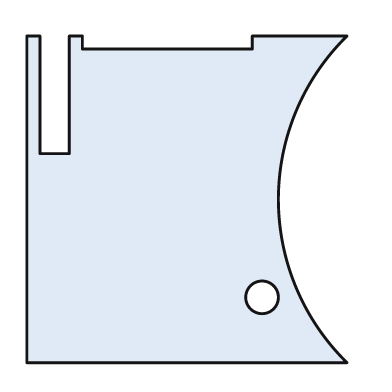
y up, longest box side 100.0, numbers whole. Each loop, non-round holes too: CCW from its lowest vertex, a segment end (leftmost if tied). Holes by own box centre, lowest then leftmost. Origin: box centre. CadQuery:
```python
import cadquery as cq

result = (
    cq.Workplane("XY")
    .moveTo(-49.0, -50.0)
    .lineTo(49.0, -50.0)
    .threePointArc((28.0, 0.0), (49.0, 50.0))
    .lineTo(20.0, 50.0)
    .lineTo(20.0, 46.0)
    .lineTo(-32.0, 46.0)
    .lineTo(-32.0, 50.0)
    .lineTo(-36.0, 50.0)
    .lineTo(-36.0, 14.0)
    .lineTo(-45.0, 14.0)
    .lineTo(-45.0, 50.0)
    .lineTo(-49.0, 50.0)
    .close()
    .moveTo(23.0, -30.0)
    .circle(5.0)
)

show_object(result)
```